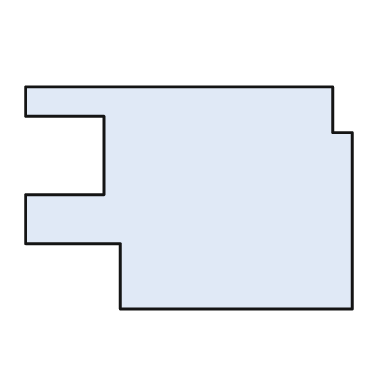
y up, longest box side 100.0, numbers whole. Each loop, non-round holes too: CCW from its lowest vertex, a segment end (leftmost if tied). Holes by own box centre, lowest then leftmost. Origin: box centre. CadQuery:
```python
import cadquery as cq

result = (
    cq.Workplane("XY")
    .moveTo(-21.0, -34.0)
    .lineTo(50.0, -34.0)
    .lineTo(50.0, 20.0)
    .lineTo(44.0, 20.0)
    .lineTo(44.0, 34.0)
    .lineTo(-50.0, 34.0)
    .lineTo(-50.0, 25.0)
    .lineTo(-26.0, 25.0)
    .lineTo(-26.0, 1.0)
    .lineTo(-50.0, 1.0)
    .lineTo(-50.0, -14.0)
    .lineTo(-21.0, -14.0)
    .close()
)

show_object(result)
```